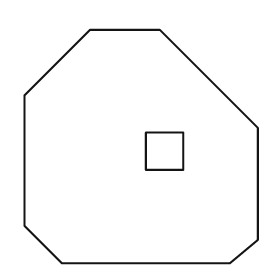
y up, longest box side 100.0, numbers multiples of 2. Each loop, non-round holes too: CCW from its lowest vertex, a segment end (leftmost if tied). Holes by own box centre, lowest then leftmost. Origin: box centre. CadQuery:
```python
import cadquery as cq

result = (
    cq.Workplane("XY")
    .moveTo(-34.0, -50.0)
    .lineTo(38.0, -50.0)
    .lineTo(50.0, -40.0)
    .lineTo(50.0, 8.0)
    .lineTo(8.0, 50.0)
    .lineTo(-22.0, 50.0)
    .lineTo(-50.0, 22.0)
    .lineTo(-50.0, -34.0)
    .close()
    .moveTo(2.0, -10.0)
    .lineTo(18.0, -10.0)
    .lineTo(18.0, 6.0)
    .lineTo(2.0, 6.0)
    .close()
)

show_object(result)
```